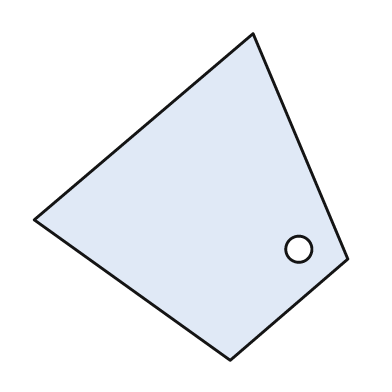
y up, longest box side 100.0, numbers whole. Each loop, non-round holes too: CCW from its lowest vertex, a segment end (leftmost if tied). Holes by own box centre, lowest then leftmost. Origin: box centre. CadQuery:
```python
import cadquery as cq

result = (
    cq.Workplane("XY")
    .moveTo(12.0, -50.0)
    .lineTo(48.0, -19.0)
    .lineTo(19.0, 50.0)
    .lineTo(-48.0, -7.0)
    .close()
    .moveTo(33.0, -16.0)
    .circle(4.0)
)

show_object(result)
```